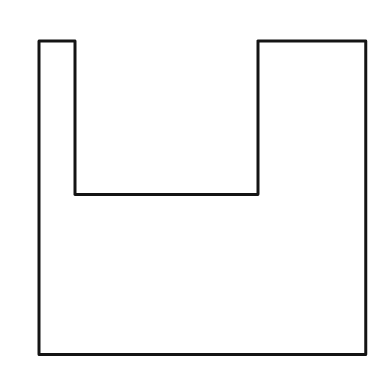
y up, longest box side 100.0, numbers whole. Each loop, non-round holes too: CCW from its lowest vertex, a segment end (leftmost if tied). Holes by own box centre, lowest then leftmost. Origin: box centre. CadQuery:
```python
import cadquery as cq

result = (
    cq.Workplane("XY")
    .moveTo(-50.0, -48.0)
    .lineTo(50.0, -48.0)
    .lineTo(50.0, 48.0)
    .lineTo(17.0, 48.0)
    .lineTo(17.0, 1.0)
    .lineTo(-39.0, 1.0)
    .lineTo(-39.0, 48.0)
    .lineTo(-50.0, 48.0)
    .close()
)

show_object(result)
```